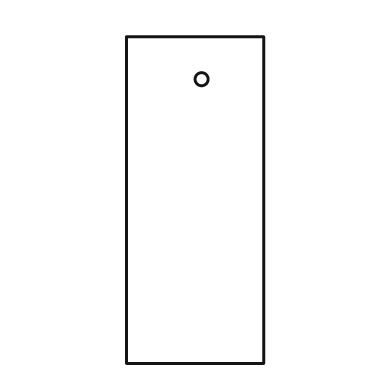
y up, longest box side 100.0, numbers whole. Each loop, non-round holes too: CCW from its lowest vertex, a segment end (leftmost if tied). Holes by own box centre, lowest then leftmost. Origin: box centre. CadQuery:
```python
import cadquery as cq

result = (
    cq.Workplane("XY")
    .moveTo(-21.0, -50.0)
    .lineTo(21.0, -50.0)
    .lineTo(21.0, 50.0)
    .lineTo(-21.0, 50.0)
    .close()
    .moveTo(2.0, 37.0)
    .circle(2.0)
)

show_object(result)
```